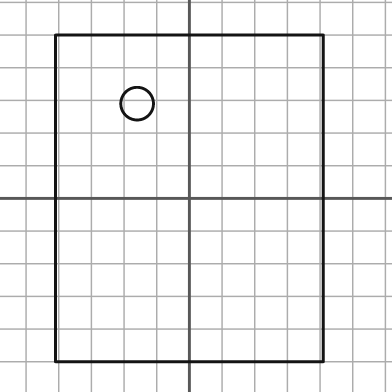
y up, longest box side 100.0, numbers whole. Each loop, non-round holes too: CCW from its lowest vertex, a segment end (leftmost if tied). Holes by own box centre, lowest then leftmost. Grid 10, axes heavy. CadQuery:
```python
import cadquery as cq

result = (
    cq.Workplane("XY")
    .moveTo(-41.0, -50.0)
    .lineTo(41.0, -50.0)
    .lineTo(41.0, 50.0)
    .lineTo(-41.0, 50.0)
    .close()
    .moveTo(-16.0, 29.0)
    .circle(5.0)
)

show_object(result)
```